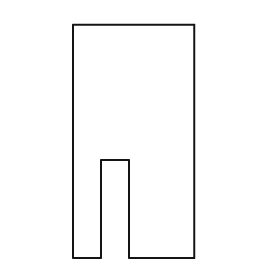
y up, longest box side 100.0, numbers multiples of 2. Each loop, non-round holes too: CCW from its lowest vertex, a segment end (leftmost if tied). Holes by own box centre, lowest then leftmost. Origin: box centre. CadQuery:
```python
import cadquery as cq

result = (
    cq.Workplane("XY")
    .moveTo(-26.0, -50.0)
    .lineTo(-14.0, -50.0)
    .lineTo(-14.0, -8.0)
    .lineTo(-2.0, -8.0)
    .lineTo(-2.0, -50.0)
    .lineTo(26.0, -50.0)
    .lineTo(26.0, 50.0)
    .lineTo(-26.0, 50.0)
    .close()
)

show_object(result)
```